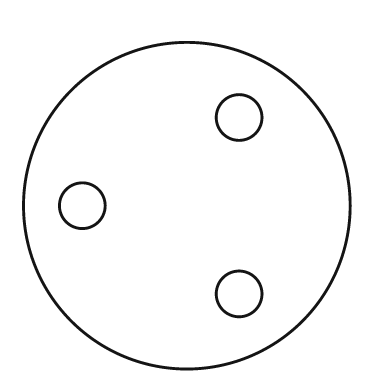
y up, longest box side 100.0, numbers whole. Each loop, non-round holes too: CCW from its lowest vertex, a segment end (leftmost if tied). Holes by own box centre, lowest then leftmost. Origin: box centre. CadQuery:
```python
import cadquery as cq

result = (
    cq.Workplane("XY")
    .moveTo(0.0, 0.0)
    .circle(50.0)
    .moveTo(16.0, -27.0)
    .circle(7.0)
    .moveTo(-32.0, 0.0)
    .circle(7.0)
    .moveTo(16.0, 27.0)
    .circle(7.0)
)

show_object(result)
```